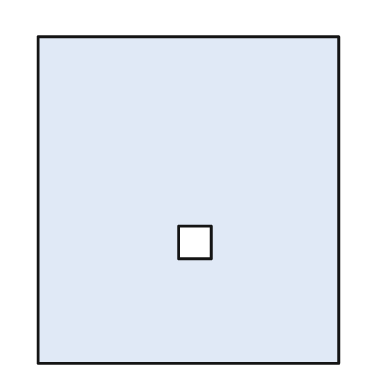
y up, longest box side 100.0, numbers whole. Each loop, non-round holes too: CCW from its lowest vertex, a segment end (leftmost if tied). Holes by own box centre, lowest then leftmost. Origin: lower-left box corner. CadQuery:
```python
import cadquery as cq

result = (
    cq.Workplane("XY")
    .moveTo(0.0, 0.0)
    .lineTo(92.0, 0.0)
    .lineTo(92.0, 100.0)
    .lineTo(0.0, 100.0)
    .close()
    .moveTo(43.0, 32.0)
    .lineTo(53.0, 32.0)
    .lineTo(53.0, 42.0)
    .lineTo(43.0, 42.0)
    .close()
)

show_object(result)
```